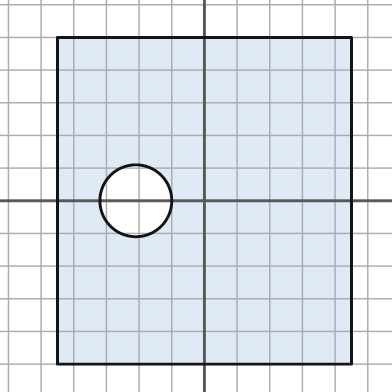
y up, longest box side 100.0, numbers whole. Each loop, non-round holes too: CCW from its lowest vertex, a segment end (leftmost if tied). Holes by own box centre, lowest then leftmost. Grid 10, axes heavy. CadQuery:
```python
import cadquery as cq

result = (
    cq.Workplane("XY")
    .moveTo(-45.0, -50.0)
    .lineTo(45.0, -50.0)
    .lineTo(45.0, 50.0)
    .lineTo(-45.0, 50.0)
    .close()
    .moveTo(-21.0, 0.0)
    .circle(11.0)
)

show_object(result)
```